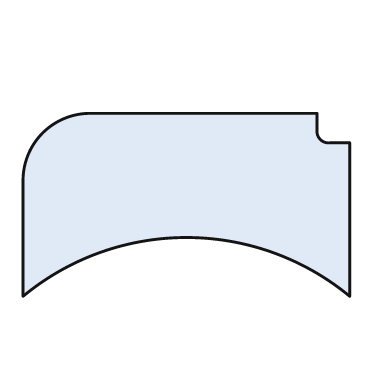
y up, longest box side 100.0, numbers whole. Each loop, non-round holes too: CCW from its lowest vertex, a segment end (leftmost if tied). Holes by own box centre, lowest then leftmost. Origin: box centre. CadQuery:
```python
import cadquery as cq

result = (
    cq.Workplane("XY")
    .moveTo(-50.0, -28.0)
    .threePointArc((0.0, -10.0), (50.0, -28.0))
    .lineTo(50.0, 19.0)
    .lineTo(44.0, 19.0)
    .threePointArc((41.0, 20.0), (40.0, 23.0))
    .lineTo(40.0, 28.0)
    .lineTo(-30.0, 28.0)
    .threePointArc((-44.0, 22.0), (-50.0, 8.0))
    .close()
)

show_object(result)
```